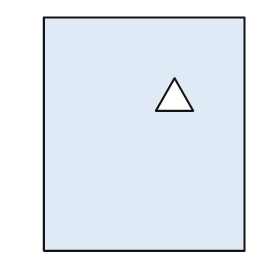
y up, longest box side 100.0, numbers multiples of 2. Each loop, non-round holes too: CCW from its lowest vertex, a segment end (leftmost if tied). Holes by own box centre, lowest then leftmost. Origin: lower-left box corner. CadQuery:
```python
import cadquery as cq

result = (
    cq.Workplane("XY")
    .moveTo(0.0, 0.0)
    .lineTo(86.0, 0.0)
    .lineTo(86.0, 100.0)
    .lineTo(0.0, 100.0)
    .close()
    .moveTo(48.0, 60.0)
    .lineTo(64.0, 60.0)
    .lineTo(56.0, 74.0)
    .close()
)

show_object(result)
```